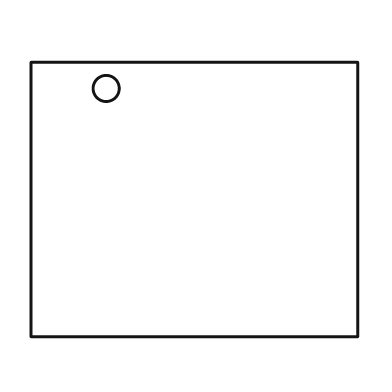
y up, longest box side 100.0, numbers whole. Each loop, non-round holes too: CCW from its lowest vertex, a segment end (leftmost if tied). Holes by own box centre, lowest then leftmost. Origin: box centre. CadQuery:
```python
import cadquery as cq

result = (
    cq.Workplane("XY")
    .moveTo(-50.0, -42.0)
    .lineTo(50.0, -42.0)
    .lineTo(50.0, 42.0)
    .lineTo(-50.0, 42.0)
    .close()
    .moveTo(-27.0, 34.0)
    .circle(4.0)
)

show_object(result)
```